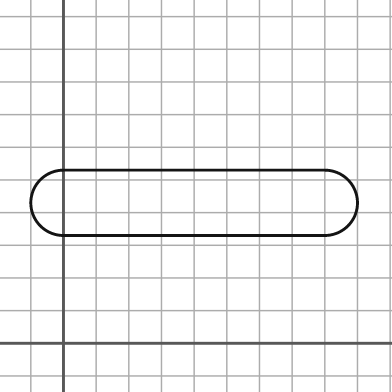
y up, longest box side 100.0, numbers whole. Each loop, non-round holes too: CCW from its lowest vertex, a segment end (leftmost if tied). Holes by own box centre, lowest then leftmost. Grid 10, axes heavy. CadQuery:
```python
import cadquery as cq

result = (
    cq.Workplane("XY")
    .moveTo(0.0, 33.0)
    .lineTo(80.0, 33.0)
    .threePointArc((90.0, 43.0), (80.0, 53.0))
    .lineTo(0.0, 53.0)
    .threePointArc((-10.0, 43.0), (0.0, 33.0))
    .close()
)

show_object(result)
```